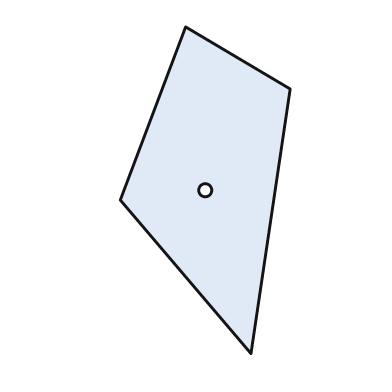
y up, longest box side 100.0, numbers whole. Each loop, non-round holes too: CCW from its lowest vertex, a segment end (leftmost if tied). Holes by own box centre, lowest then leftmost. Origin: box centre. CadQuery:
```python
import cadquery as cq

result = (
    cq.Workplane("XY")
    .moveTo(14.0, -50.0)
    .lineTo(26.0, 31.0)
    .lineTo(-6.0, 50.0)
    .lineTo(-26.0, -3.0)
    .close()
    .moveTo(0.0, 0.0)
    .circle(2.0)
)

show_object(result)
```